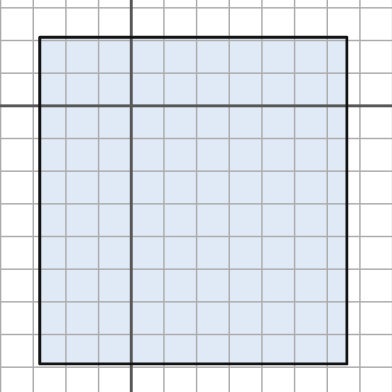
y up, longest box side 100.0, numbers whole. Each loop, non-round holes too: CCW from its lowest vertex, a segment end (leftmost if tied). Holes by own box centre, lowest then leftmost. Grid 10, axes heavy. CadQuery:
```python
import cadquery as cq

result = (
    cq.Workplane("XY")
    .moveTo(-28.0, -79.0)
    .lineTo(66.0, -79.0)
    .lineTo(66.0, 21.0)
    .lineTo(-28.0, 21.0)
    .close()
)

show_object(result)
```